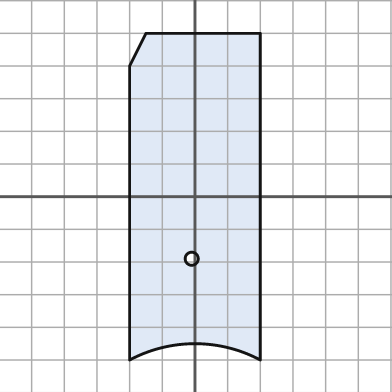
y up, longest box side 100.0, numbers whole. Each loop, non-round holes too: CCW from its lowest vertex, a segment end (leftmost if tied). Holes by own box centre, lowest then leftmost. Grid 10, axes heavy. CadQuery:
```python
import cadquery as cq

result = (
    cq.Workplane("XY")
    .moveTo(-20.0, -50.0)
    .threePointArc((0.0, -45.0), (20.0, -50.0))
    .lineTo(20.0, 50.0)
    .lineTo(-15.0, 50.0)
    .lineTo(-20.0, 40.0)
    .close()
    .moveTo(-1.0, -19.0)
    .circle(2.0)
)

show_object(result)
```